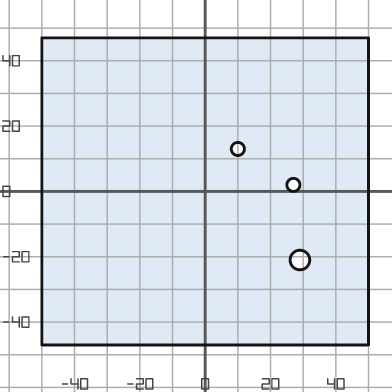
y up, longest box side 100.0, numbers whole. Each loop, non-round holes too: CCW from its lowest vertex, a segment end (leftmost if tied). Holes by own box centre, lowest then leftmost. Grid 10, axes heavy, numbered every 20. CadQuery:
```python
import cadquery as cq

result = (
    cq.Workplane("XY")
    .moveTo(-50.0, -47.0)
    .lineTo(50.0, -47.0)
    .lineTo(50.0, 47.0)
    .lineTo(-50.0, 47.0)
    .close()
    .moveTo(29.0, -21.0)
    .circle(3.0)
    .moveTo(27.0, 2.0)
    .circle(2.0)
    .moveTo(10.0, 13.0)
    .circle(2.0)
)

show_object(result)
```